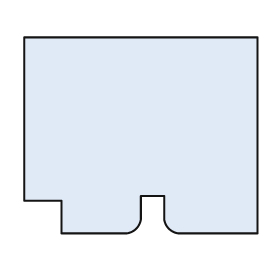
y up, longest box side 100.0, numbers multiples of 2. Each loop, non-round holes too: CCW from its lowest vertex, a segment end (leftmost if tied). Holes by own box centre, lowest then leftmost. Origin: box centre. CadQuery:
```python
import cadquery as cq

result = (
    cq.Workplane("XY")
    .moveTo(-34.0, -42.0)
    .lineTo(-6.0, -42.0)
    .threePointArc((-2.0, -40.0), (0.0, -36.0))
    .lineTo(0.0, -26.0)
    .lineTo(10.0, -26.0)
    .lineTo(10.0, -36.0)
    .threePointArc((12.0, -40.0), (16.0, -42.0))
    .lineTo(50.0, -42.0)
    .lineTo(50.0, 42.0)
    .lineTo(-50.0, 42.0)
    .lineTo(-50.0, -28.0)
    .lineTo(-34.0, -28.0)
    .close()
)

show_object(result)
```